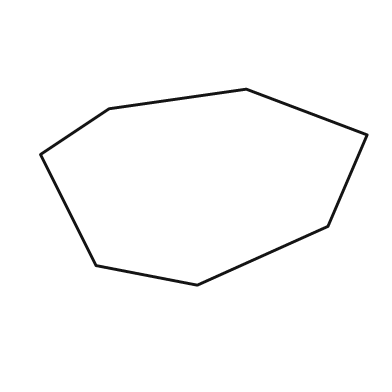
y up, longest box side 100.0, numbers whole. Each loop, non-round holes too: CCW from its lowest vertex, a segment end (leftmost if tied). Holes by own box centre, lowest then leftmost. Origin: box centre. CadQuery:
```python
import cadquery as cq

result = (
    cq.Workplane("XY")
    .moveTo(-2.0, -30.0)
    .lineTo(38.0, -12.0)
    .lineTo(50.0, 16.0)
    .lineTo(13.0, 30.0)
    .lineTo(-29.0, 24.0)
    .lineTo(-50.0, 10.0)
    .lineTo(-33.0, -24.0)
    .close()
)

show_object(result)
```